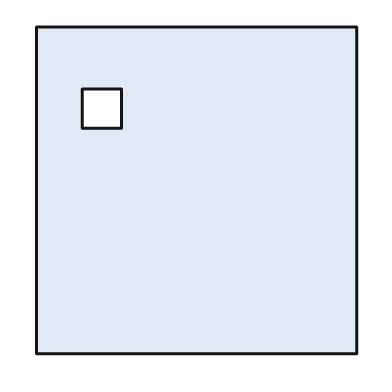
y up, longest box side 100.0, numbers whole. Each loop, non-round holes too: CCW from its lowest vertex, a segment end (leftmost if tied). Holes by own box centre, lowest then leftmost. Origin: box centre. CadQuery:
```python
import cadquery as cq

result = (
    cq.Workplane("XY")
    .moveTo(-49.0, -50.0)
    .lineTo(49.0, -50.0)
    .lineTo(49.0, 50.0)
    .lineTo(-49.0, 50.0)
    .close()
    .moveTo(-35.0, 19.0)
    .lineTo(-23.0, 19.0)
    .lineTo(-23.0, 31.0)
    .lineTo(-35.0, 31.0)
    .close()
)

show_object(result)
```